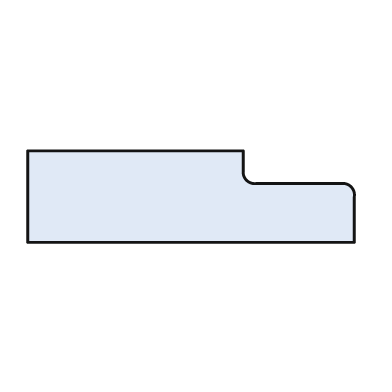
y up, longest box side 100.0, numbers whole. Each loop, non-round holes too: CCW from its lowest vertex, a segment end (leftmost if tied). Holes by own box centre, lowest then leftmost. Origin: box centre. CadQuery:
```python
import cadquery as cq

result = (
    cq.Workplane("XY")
    .moveTo(-50.0, -14.0)
    .lineTo(50.0, -14.0)
    .lineTo(50.0, 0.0)
    .threePointArc((49.0, 3.0), (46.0, 4.0))
    .lineTo(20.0, 4.0)
    .threePointArc((17.0, 5.0), (16.0, 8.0))
    .lineTo(16.0, 14.0)
    .lineTo(-50.0, 14.0)
    .close()
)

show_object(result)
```